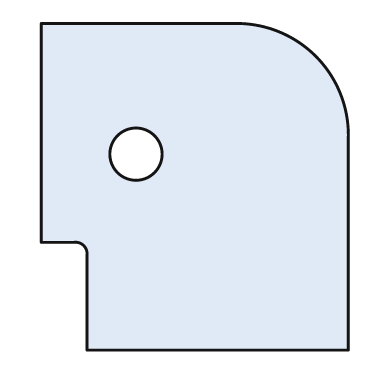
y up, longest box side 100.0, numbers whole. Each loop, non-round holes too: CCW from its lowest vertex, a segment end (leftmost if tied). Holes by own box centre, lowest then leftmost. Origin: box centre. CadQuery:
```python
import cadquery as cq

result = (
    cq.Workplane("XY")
    .moveTo(-33.0, -50.0)
    .lineTo(47.0, -50.0)
    .lineTo(47.0, 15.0)
    .threePointArc((37.0, 40.0), (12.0, 50.0))
    .lineTo(-47.0, 50.0)
    .lineTo(-47.0, -17.0)
    .lineTo(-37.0, -17.0)
    .threePointArc((-34.0, -18.0), (-33.0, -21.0))
    .close()
    .moveTo(-18.0, 10.0)
    .circle(8.0)
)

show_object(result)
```